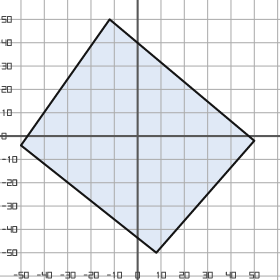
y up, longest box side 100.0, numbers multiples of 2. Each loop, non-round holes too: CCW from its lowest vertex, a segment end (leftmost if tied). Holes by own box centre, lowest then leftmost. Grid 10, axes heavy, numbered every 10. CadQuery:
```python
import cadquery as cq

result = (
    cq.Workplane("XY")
    .moveTo(8.0, -50.0)
    .lineTo(50.0, -2.0)
    .lineTo(-12.0, 50.0)
    .lineTo(-50.0, -4.0)
    .close()
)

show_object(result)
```